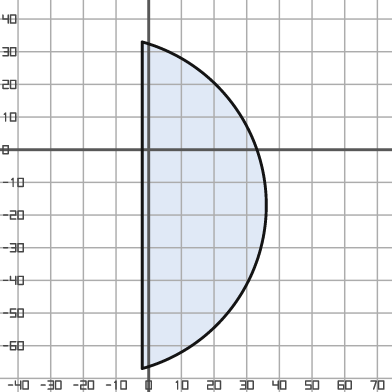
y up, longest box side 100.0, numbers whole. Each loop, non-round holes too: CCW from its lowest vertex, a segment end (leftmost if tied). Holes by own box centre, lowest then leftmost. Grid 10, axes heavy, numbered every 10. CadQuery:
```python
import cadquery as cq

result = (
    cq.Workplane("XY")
    .moveTo(-2.0, -67.0)
    .threePointArc((36.0, -17.0), (-2.0, 33.0))
    .close()
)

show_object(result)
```